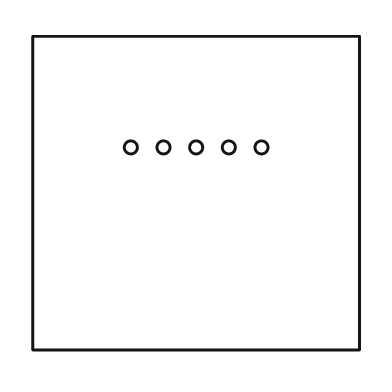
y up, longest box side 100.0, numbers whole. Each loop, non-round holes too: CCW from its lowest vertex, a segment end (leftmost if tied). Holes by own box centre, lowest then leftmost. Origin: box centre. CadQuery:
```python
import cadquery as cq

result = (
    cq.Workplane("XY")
    .moveTo(-50.0, -48.0)
    .lineTo(50.0, -48.0)
    .lineTo(50.0, 48.0)
    .lineTo(-50.0, 48.0)
    .close()
    .moveTo(-20.0, 14.0)
    .circle(2.0)
    .moveTo(-10.0, 14.0)
    .circle(2.0)
    .moveTo(0.0, 14.0)
    .circle(2.0)
    .moveTo(10.0, 14.0)
    .circle(2.0)
    .moveTo(20.0, 14.0)
    .circle(2.0)
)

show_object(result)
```